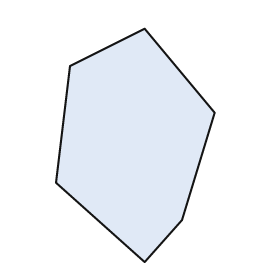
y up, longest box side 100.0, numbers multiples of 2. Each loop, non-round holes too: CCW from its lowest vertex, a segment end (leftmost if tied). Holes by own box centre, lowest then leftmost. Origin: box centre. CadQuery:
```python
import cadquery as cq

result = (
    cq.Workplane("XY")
    .moveTo(4.0, -50.0)
    .lineTo(20.0, -32.0)
    .lineTo(34.0, 14.0)
    .lineTo(4.0, 50.0)
    .lineTo(-28.0, 34.0)
    .lineTo(-34.0, -16.0)
    .close()
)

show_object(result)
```